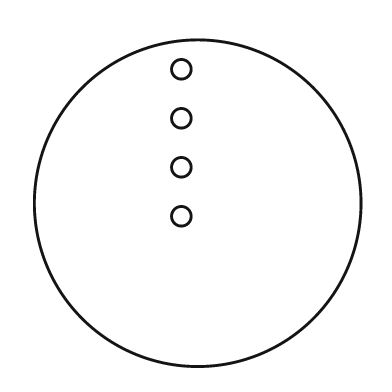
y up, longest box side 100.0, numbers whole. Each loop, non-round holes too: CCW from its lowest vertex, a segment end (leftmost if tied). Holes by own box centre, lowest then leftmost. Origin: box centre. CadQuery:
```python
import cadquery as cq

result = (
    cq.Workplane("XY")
    .moveTo(0.0, 0.0)
    .circle(50.0)
    .moveTo(-5.0, -4.0)
    .circle(3.0)
    .moveTo(-5.0, 11.0)
    .circle(3.0)
    .moveTo(-5.0, 26.0)
    .circle(3.0)
    .moveTo(-5.0, 41.0)
    .circle(3.0)
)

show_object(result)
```